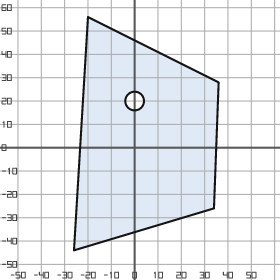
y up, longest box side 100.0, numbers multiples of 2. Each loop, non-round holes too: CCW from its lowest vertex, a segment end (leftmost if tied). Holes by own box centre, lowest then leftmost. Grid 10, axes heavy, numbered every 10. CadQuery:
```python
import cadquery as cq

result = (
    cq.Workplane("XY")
    .moveTo(-26.0, -44.0)
    .lineTo(34.0, -26.0)
    .lineTo(36.0, 28.0)
    .lineTo(-20.0, 56.0)
    .close()
    .moveTo(0.0, 20.0)
    .circle(4.0)
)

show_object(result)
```